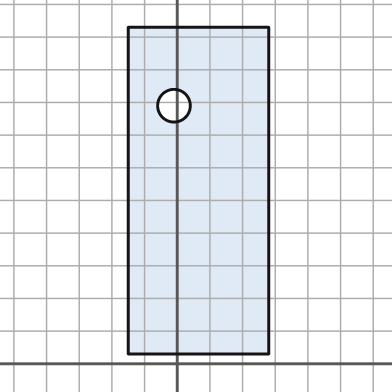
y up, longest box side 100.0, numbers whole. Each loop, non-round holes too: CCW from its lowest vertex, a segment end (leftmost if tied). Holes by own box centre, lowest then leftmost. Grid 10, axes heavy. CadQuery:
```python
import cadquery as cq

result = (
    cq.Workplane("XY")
    .moveTo(-15.0, 3.0)
    .lineTo(28.0, 3.0)
    .lineTo(28.0, 103.0)
    .lineTo(-15.0, 103.0)
    .close()
    .moveTo(-1.0, 79.0)
    .circle(5.0)
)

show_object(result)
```